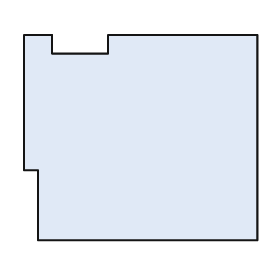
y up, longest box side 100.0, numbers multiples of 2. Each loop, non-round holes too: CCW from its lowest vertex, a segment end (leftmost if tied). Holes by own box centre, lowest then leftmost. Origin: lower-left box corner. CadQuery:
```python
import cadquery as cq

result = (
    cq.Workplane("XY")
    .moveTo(6.0, 0.0)
    .lineTo(100.0, 0.0)
    .lineTo(100.0, 88.0)
    .lineTo(36.0, 88.0)
    .lineTo(36.0, 80.0)
    .lineTo(12.0, 80.0)
    .lineTo(12.0, 88.0)
    .lineTo(0.0, 88.0)
    .lineTo(0.0, 30.0)
    .lineTo(6.0, 30.0)
    .close()
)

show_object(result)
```